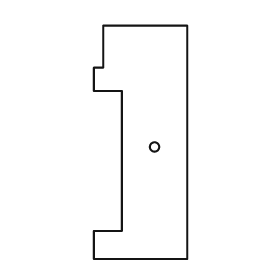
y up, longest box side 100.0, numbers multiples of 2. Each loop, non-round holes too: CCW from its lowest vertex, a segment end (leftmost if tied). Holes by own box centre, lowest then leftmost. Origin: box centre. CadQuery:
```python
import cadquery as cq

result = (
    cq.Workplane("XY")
    .moveTo(-20.0, -50.0)
    .lineTo(20.0, -50.0)
    .lineTo(20.0, 50.0)
    .lineTo(-16.0, 50.0)
    .lineTo(-16.0, 32.0)
    .lineTo(-20.0, 32.0)
    .lineTo(-20.0, 22.0)
    .lineTo(-8.0, 22.0)
    .lineTo(-8.0, -38.0)
    .lineTo(-20.0, -38.0)
    .close()
    .moveTo(6.0, -2.0)
    .circle(2.0)
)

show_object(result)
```